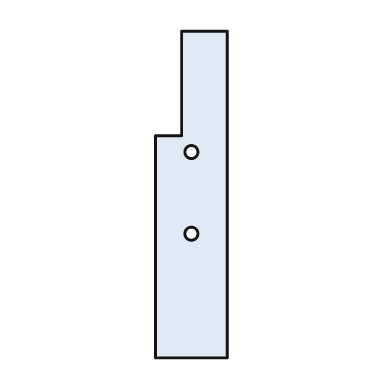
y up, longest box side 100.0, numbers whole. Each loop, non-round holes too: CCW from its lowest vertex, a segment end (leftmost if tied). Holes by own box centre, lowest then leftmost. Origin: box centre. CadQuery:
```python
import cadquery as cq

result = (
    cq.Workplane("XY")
    .moveTo(-11.0, -50.0)
    .lineTo(11.0, -50.0)
    .lineTo(11.0, 50.0)
    .lineTo(-3.0, 50.0)
    .lineTo(-3.0, 18.0)
    .lineTo(-11.0, 18.0)
    .close()
    .moveTo(0.0, -12.0)
    .circle(2.0)
    .moveTo(0.0, 13.0)
    .circle(2.0)
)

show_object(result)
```